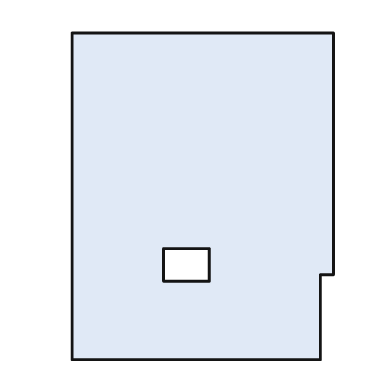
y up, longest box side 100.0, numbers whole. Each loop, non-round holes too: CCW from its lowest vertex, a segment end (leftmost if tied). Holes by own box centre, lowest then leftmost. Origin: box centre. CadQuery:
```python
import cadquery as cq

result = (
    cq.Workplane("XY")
    .moveTo(-40.0, -50.0)
    .lineTo(36.0, -50.0)
    .lineTo(36.0, -24.0)
    .lineTo(40.0, -24.0)
    .lineTo(40.0, 50.0)
    .lineTo(-40.0, 50.0)
    .close()
    .moveTo(-12.0, -26.0)
    .lineTo(2.0, -26.0)
    .lineTo(2.0, -16.0)
    .lineTo(-12.0, -16.0)
    .close()
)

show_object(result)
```